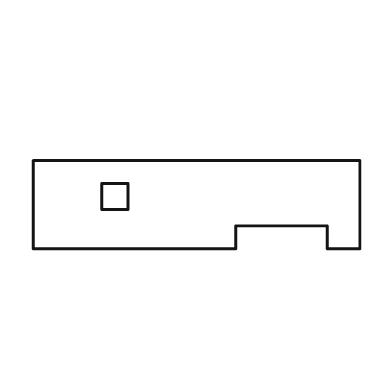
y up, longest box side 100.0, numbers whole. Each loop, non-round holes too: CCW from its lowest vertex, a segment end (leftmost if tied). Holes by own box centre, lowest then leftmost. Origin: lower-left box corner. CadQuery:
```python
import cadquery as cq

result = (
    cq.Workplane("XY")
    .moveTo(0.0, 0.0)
    .lineTo(62.0, 0.0)
    .lineTo(62.0, 7.0)
    .lineTo(90.0, 7.0)
    .lineTo(90.0, 0.0)
    .lineTo(100.0, 0.0)
    .lineTo(100.0, 27.0)
    .lineTo(0.0, 27.0)
    .close()
    .moveTo(21.0, 12.0)
    .lineTo(29.0, 12.0)
    .lineTo(29.0, 20.0)
    .lineTo(21.0, 20.0)
    .close()
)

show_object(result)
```